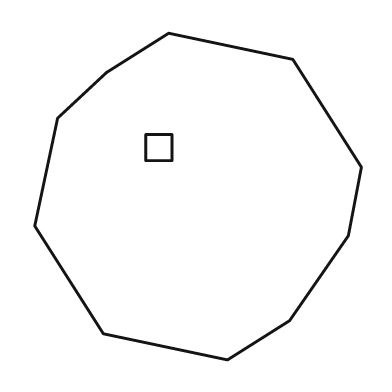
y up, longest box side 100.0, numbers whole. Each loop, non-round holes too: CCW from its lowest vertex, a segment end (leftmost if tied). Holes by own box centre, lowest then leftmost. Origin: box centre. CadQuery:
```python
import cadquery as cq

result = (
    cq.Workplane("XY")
    .moveTo(9.0, -50.0)
    .lineTo(28.0, -38.0)
    .lineTo(46.0, -12.0)
    .lineTo(50.0, 9.0)
    .lineTo(29.0, 42.0)
    .lineTo(-9.0, 50.0)
    .lineTo(-28.0, 38.0)
    .lineTo(-43.0, 24.0)
    .lineTo(-50.0, -9.0)
    .lineTo(-29.0, -42.0)
    .close()
    .moveTo(-16.0, 11.0)
    .lineTo(-8.0, 11.0)
    .lineTo(-8.0, 19.0)
    .lineTo(-16.0, 19.0)
    .close()
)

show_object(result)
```